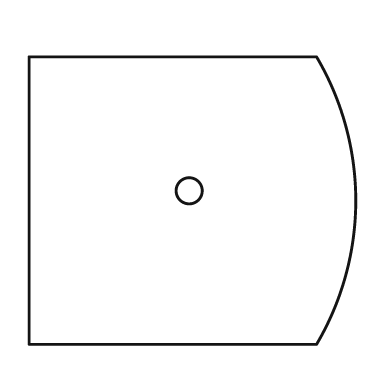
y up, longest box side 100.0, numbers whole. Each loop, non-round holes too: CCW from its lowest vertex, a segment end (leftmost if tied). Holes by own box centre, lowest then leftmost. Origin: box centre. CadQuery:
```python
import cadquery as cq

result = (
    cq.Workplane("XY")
    .moveTo(-50.0, -44.0)
    .lineTo(38.0, -44.0)
    .threePointArc((50.0, 0.0), (38.0, 44.0))
    .lineTo(-50.0, 44.0)
    .close()
    .moveTo(-1.0, 3.0)
    .circle(4.0)
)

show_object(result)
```